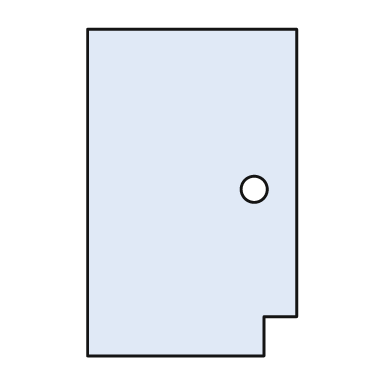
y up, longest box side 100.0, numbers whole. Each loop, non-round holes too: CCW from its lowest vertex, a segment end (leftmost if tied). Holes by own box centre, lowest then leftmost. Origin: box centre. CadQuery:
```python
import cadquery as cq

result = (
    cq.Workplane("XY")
    .moveTo(-32.0, -50.0)
    .lineTo(22.0, -50.0)
    .lineTo(22.0, -38.0)
    .lineTo(32.0, -38.0)
    .lineTo(32.0, 50.0)
    .lineTo(-32.0, 50.0)
    .close()
    .moveTo(19.0, 1.0)
    .circle(4.0)
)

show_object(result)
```